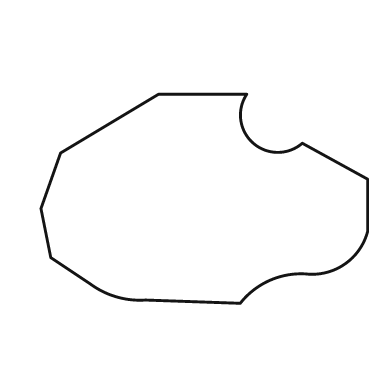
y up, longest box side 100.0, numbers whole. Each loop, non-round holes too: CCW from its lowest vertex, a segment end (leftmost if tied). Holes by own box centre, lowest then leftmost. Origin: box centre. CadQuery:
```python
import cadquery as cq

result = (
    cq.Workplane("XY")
    .moveTo(11.0, -32.0)
    .threePointArc((20.0, -25.0), (31.0, -23.0))
    .threePointArc((43.0, -20.0), (50.0, -10.0))
    .lineTo(50.0, 6.0)
    .lineTo(30.0, 17.0)
    .threePointArc((15.0, 17.0), (13.0, 32.0))
    .lineTo(-14.0, 32.0)
    .lineTo(-44.0, 14.0)
    .lineTo(-50.0, -3.0)
    .lineTo(-47.0, -18.0)
    .lineTo(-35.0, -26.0)
    .threePointArc((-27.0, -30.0), (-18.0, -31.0))
    .close()
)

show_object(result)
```